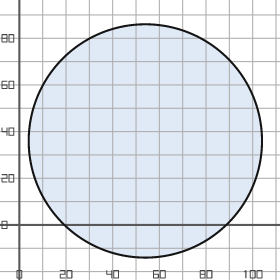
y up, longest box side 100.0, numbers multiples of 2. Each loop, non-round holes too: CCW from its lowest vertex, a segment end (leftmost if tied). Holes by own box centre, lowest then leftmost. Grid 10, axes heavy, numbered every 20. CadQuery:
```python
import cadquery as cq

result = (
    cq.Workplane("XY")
    .moveTo(54.0, 36.0)
    .circle(50.0)
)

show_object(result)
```